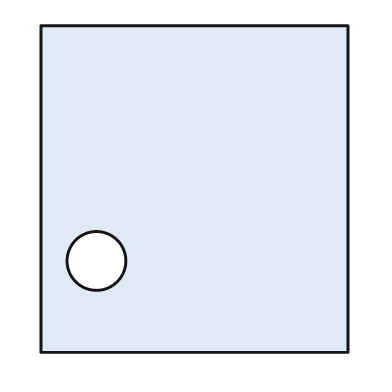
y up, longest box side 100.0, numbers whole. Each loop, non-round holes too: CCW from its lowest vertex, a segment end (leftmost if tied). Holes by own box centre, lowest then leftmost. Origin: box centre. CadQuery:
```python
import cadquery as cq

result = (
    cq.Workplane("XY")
    .moveTo(-47.0, -50.0)
    .lineTo(47.0, -50.0)
    .lineTo(47.0, 50.0)
    .lineTo(-47.0, 50.0)
    .close()
    .moveTo(-30.0, -22.0)
    .circle(9.0)
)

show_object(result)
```